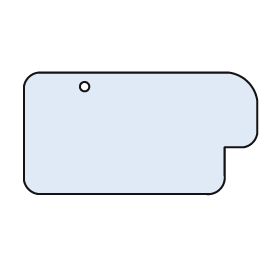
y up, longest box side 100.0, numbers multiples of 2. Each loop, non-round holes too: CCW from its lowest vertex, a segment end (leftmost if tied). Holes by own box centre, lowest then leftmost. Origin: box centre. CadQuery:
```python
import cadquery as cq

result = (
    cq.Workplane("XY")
    .moveTo(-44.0, -26.0)
    .lineTo(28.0, -26.0)
    .threePointArc((34.0, -24.0), (36.0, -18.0))
    .lineTo(36.0, -6.0)
    .lineTo(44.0, -6.0)
    .threePointArc((48.0, -4.0), (50.0, 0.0))
    .lineTo(50.0, 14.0)
    .threePointArc((46.0, 22.0), (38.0, 26.0))
    .lineTo(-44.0, 26.0)
    .threePointArc((-48.0, 24.0), (-50.0, 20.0))
    .lineTo(-50.0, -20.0)
    .threePointArc((-48.0, -24.0), (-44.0, -26.0))
    .close()
    .moveTo(-24.0, 20.0)
    .circle(2.0)
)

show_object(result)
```